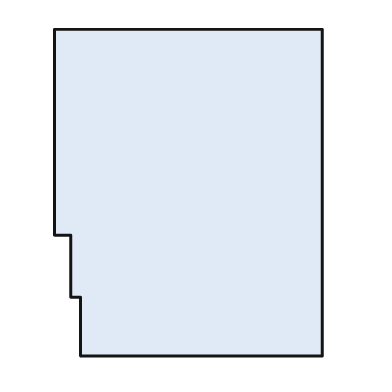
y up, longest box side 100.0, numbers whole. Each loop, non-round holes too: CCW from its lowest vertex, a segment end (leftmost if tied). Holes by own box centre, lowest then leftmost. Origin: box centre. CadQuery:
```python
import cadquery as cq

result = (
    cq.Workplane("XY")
    .moveTo(-33.0, -50.0)
    .lineTo(41.0, -50.0)
    .lineTo(41.0, 50.0)
    .lineTo(-41.0, 50.0)
    .lineTo(-41.0, -13.0)
    .lineTo(-36.0, -13.0)
    .lineTo(-36.0, -32.0)
    .lineTo(-33.0, -32.0)
    .close()
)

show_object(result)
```